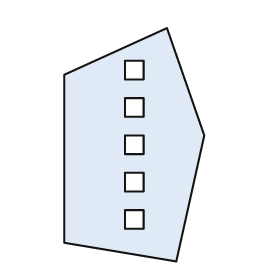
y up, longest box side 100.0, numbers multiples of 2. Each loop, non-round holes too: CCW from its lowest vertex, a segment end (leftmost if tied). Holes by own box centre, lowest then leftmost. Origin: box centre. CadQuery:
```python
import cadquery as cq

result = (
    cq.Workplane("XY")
    .moveTo(18.0, -50.0)
    .lineTo(30.0, 4.0)
    .lineTo(14.0, 50.0)
    .lineTo(-30.0, 30.0)
    .lineTo(-30.0, -42.0)
    .close()
    .moveTo(-4.0, -36.0)
    .lineTo(4.0, -36.0)
    .lineTo(4.0, -28.0)
    .lineTo(-4.0, -28.0)
    .close()
    .moveTo(-4.0, -20.0)
    .lineTo(4.0, -20.0)
    .lineTo(4.0, -12.0)
    .lineTo(-4.0, -12.0)
    .close()
    .moveTo(-4.0, -4.0)
    .lineTo(4.0, -4.0)
    .lineTo(4.0, 4.0)
    .lineTo(-4.0, 4.0)
    .close()
    .moveTo(-4.0, 12.0)
    .lineTo(4.0, 12.0)
    .lineTo(4.0, 20.0)
    .lineTo(-4.0, 20.0)
    .close()
    .moveTo(-4.0, 28.0)
    .lineTo(4.0, 28.0)
    .lineTo(4.0, 36.0)
    .lineTo(-4.0, 36.0)
    .close()
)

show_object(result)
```